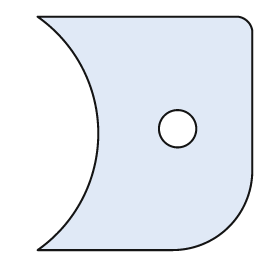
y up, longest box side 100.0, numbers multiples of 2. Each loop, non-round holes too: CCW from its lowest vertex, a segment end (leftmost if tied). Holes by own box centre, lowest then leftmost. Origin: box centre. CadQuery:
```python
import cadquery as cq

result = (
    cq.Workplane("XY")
    .moveTo(-46.0, -50.0)
    .lineTo(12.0, -50.0)
    .threePointArc((36.0, -40.0), (46.0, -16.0))
    .lineTo(46.0, 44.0)
    .threePointArc((44.0, 48.0), (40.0, 50.0))
    .lineTo(-46.0, 50.0)
    .threePointArc((-20.0, 0.0), (-46.0, -50.0))
    .close()
    .moveTo(14.0, 2.0)
    .circle(8.0)
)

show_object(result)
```